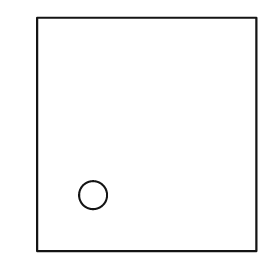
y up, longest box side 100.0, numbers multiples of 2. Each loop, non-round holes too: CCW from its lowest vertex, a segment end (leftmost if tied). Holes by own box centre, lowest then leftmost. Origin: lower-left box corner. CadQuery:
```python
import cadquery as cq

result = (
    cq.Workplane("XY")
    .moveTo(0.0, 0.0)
    .lineTo(94.0, 0.0)
    .lineTo(94.0, 100.0)
    .lineTo(0.0, 100.0)
    .close()
    .moveTo(24.0, 24.0)
    .circle(6.0)
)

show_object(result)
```